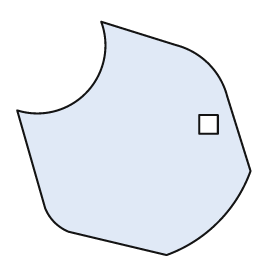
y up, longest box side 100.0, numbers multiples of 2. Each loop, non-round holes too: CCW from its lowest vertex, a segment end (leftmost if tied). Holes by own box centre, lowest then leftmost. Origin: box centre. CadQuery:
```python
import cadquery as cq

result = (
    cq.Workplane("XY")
    .moveTo(14.0, -50.0)
    .threePointArc((36.0, -36.0), (50.0, -14.0))
    .lineTo(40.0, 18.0)
    .threePointArc((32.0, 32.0), (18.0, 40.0))
    .lineTo(-14.0, 50.0)
    .threePointArc((-20.0, 20.0), (-50.0, 12.0))
    .lineTo(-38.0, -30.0)
    .threePointArc((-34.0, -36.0), (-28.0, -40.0))
    .close()
    .moveTo(28.0, 2.0)
    .lineTo(36.0, 2.0)
    .lineTo(36.0, 10.0)
    .lineTo(28.0, 10.0)
    .close()
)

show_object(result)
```